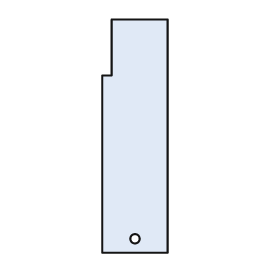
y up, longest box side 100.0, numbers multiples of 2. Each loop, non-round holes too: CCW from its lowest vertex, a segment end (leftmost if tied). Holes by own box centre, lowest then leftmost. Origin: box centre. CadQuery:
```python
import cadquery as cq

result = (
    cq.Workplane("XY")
    .moveTo(-14.0, -50.0)
    .lineTo(14.0, -50.0)
    .lineTo(14.0, 50.0)
    .lineTo(-10.0, 50.0)
    .lineTo(-10.0, 26.0)
    .lineTo(-14.0, 26.0)
    .close()
    .moveTo(0.0, -44.0)
    .circle(2.0)
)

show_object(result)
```